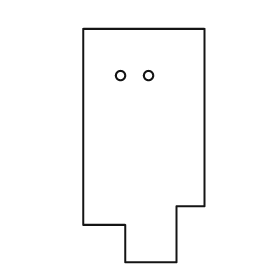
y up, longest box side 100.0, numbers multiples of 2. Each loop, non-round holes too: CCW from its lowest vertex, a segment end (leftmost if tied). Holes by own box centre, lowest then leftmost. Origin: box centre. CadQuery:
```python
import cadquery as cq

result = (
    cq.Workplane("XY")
    .moveTo(-8.0, -50.0)
    .lineTo(14.0, -50.0)
    .lineTo(14.0, -26.0)
    .lineTo(26.0, -26.0)
    .lineTo(26.0, 50.0)
    .lineTo(-26.0, 50.0)
    .lineTo(-26.0, -34.0)
    .lineTo(-8.0, -34.0)
    .close()
    .moveTo(-10.0, 30.0)
    .circle(2.0)
    .moveTo(2.0, 30.0)
    .circle(2.0)
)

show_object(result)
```